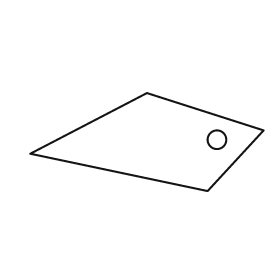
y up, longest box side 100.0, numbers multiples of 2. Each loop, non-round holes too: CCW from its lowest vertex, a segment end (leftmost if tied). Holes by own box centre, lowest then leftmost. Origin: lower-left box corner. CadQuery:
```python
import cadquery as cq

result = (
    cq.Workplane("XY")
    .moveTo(76.0, 0.0)
    .lineTo(100.0, 26.0)
    .lineTo(50.0, 42.0)
    .lineTo(0.0, 16.0)
    .close()
    .moveTo(80.0, 22.0)
    .circle(4.0)
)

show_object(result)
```